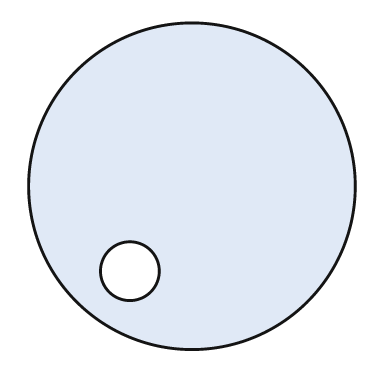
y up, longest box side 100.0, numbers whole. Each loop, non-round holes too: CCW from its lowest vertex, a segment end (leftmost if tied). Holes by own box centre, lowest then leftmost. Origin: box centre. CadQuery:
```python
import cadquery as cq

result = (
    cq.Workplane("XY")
    .moveTo(0.0, 0.0)
    .circle(50.0)
    .moveTo(-19.0, -26.0)
    .circle(9.0)
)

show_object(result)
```